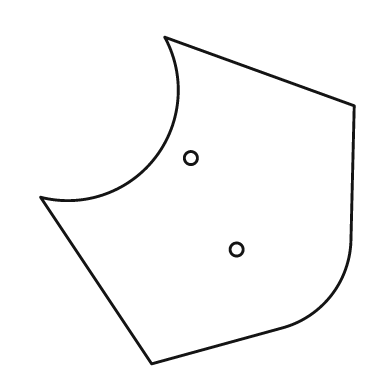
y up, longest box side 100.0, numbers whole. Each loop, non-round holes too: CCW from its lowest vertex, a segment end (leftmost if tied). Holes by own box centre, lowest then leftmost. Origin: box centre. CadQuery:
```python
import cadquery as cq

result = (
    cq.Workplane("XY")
    .moveTo(-14.0, -50.0)
    .lineTo(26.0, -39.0)
    .threePointArc((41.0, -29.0), (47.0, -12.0))
    .lineTo(48.0, 29.0)
    .lineTo(-10.0, 50.0)
    .threePointArc((-13.0, 13.0), (-48.0, 1.0))
    .close()
    .moveTo(12.0, -15.0)
    .circle(2.0)
    .moveTo(-2.0, 13.0)
    .circle(2.0)
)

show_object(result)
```